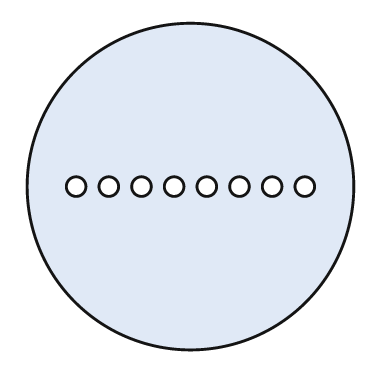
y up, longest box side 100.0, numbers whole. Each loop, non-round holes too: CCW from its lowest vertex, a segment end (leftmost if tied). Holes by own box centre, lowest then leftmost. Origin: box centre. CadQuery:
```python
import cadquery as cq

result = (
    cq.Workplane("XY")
    .moveTo(0.0, 0.0)
    .circle(50.0)
    .moveTo(-35.0, 0.0)
    .circle(3.0)
    .moveTo(-25.0, 0.0)
    .circle(3.0)
    .moveTo(-15.0, 0.0)
    .circle(3.0)
    .moveTo(-5.0, 0.0)
    .circle(3.0)
    .moveTo(5.0, 0.0)
    .circle(3.0)
    .moveTo(15.0, 0.0)
    .circle(3.0)
    .moveTo(25.0, 0.0)
    .circle(3.0)
    .moveTo(35.0, 0.0)
    .circle(3.0)
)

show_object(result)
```